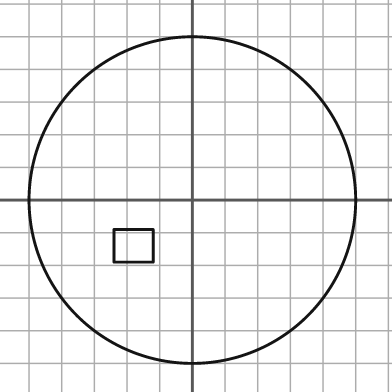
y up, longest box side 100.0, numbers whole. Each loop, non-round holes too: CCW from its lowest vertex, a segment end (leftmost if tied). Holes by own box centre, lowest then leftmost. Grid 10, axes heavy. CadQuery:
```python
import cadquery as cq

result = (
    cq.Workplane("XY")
    .moveTo(0.0, 0.0)
    .circle(50.0)
    .moveTo(-24.0, -19.0)
    .lineTo(-12.0, -19.0)
    .lineTo(-12.0, -9.0)
    .lineTo(-24.0, -9.0)
    .close()
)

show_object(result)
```